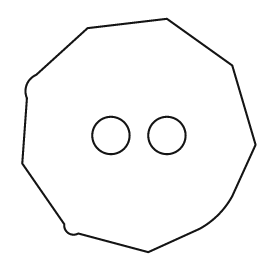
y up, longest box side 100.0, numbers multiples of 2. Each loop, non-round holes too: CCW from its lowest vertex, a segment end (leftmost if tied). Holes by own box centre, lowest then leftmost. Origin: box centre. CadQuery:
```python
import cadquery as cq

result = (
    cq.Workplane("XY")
    .moveTo(4.0, -50.0)
    .lineTo(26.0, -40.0)
    .threePointArc((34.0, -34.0), (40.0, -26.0))
    .lineTo(50.0, -4.0)
    .lineTo(40.0, 30.0)
    .lineTo(12.0, 50.0)
    .lineTo(-22.0, 46.0)
    .lineTo(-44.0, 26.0)
    .threePointArc((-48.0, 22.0), (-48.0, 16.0))
    .lineTo(-50.0, -12.0)
    .lineTo(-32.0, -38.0)
    .threePointArc((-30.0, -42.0), (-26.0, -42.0))
    .close()
    .moveTo(-12.0, 0.0)
    .circle(8.0)
    .moveTo(12.0, 0.0)
    .circle(8.0)
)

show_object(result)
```